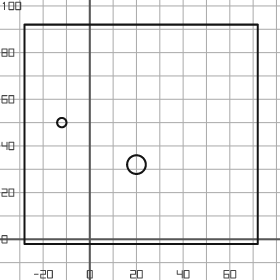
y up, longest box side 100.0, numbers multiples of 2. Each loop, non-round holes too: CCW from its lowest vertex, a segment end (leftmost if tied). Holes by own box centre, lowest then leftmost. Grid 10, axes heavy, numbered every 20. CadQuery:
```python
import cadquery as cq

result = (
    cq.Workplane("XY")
    .moveTo(-28.0, -2.0)
    .lineTo(72.0, -2.0)
    .lineTo(72.0, 92.0)
    .lineTo(-28.0, 92.0)
    .close()
    .moveTo(20.0, 32.0)
    .circle(4.0)
    .moveTo(-12.0, 50.0)
    .circle(2.0)
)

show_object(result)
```